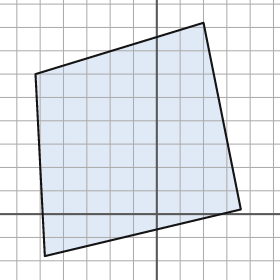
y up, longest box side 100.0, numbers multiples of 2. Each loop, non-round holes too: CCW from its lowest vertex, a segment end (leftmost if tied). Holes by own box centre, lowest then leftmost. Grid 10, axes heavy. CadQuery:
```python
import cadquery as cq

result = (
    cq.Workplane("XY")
    .moveTo(-48.0, -18.0)
    .lineTo(36.0, 2.0)
    .lineTo(20.0, 82.0)
    .lineTo(-52.0, 60.0)
    .close()
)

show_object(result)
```